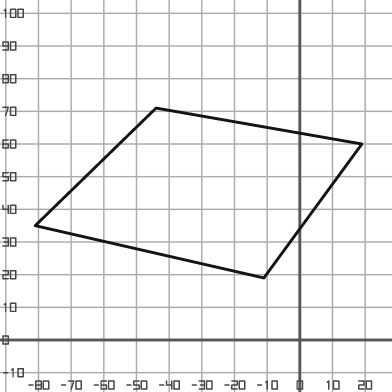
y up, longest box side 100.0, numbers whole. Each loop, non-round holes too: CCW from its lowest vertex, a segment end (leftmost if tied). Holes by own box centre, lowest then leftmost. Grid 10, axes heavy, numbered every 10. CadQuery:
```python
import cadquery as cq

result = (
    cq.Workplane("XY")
    .moveTo(-11.0, 19.0)
    .lineTo(19.0, 60.0)
    .lineTo(-44.0, 71.0)
    .lineTo(-81.0, 35.0)
    .close()
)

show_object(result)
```